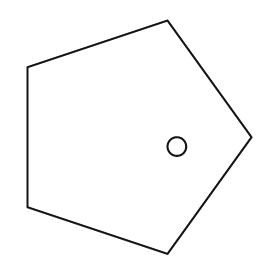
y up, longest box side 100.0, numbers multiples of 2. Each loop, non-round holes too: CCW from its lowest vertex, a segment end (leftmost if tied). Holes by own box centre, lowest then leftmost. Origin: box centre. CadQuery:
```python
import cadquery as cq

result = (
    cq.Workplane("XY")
    .moveTo(12.0, -50.0)
    .lineTo(48.0, 0.0)
    .lineTo(12.0, 50.0)
    .lineTo(-48.0, 30.0)
    .lineTo(-48.0, -30.0)
    .close()
    .moveTo(16.0, -4.0)
    .circle(4.0)
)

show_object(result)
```